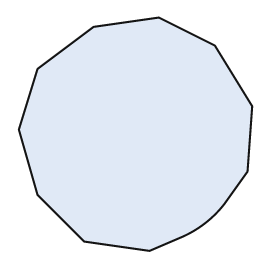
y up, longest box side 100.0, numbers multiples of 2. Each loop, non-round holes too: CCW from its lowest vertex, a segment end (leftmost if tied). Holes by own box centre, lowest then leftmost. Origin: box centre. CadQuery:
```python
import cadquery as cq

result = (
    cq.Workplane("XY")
    .moveTo(6.0, -50.0)
    .lineTo(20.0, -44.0)
    .threePointArc((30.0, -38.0), (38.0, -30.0))
    .lineTo(48.0, -16.0)
    .lineTo(50.0, 12.0)
    .lineTo(34.0, 38.0)
    .lineTo(10.0, 50.0)
    .lineTo(-18.0, 46.0)
    .lineTo(-42.0, 28.0)
    .lineTo(-50.0, 2.0)
    .lineTo(-42.0, -26.0)
    .lineTo(-22.0, -46.0)
    .close()
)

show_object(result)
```